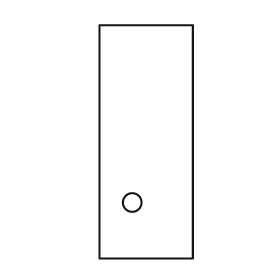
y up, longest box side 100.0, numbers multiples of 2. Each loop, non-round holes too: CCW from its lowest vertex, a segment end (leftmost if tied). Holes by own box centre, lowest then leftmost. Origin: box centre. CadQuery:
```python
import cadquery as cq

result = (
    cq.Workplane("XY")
    .moveTo(-20.0, -50.0)
    .lineTo(20.0, -50.0)
    .lineTo(20.0, 50.0)
    .lineTo(-20.0, 50.0)
    .close()
    .moveTo(-6.0, -26.0)
    .circle(4.0)
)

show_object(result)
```